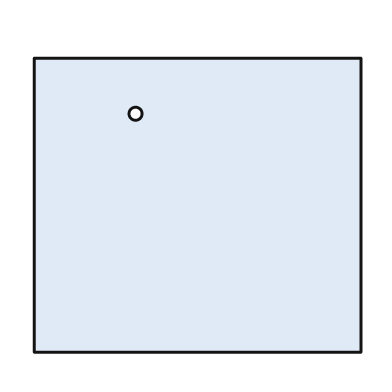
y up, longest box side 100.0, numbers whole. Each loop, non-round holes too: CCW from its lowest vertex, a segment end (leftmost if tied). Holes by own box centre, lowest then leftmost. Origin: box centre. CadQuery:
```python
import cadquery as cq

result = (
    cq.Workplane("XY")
    .moveTo(-50.0, -45.0)
    .lineTo(50.0, -45.0)
    .lineTo(50.0, 45.0)
    .lineTo(-50.0, 45.0)
    .close()
    .moveTo(-19.0, 28.0)
    .circle(2.0)
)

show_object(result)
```